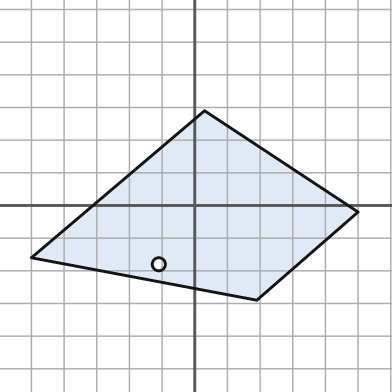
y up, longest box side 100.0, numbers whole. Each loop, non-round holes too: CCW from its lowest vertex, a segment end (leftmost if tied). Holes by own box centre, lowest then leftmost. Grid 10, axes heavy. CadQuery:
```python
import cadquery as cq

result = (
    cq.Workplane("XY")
    .moveTo(19.0, -29.0)
    .lineTo(50.0, -2.0)
    .lineTo(3.0, 29.0)
    .lineTo(-50.0, -16.0)
    .close()
    .moveTo(-11.0, -18.0)
    .circle(2.0)
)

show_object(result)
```